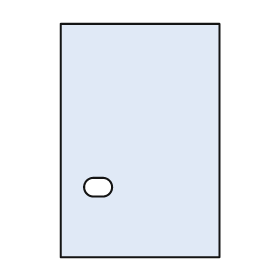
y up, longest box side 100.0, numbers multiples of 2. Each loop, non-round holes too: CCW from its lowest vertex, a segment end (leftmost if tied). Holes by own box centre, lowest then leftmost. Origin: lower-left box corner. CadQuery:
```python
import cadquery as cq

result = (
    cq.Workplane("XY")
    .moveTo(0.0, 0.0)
    .lineTo(68.0, 0.0)
    .lineTo(68.0, 100.0)
    .lineTo(0.0, 100.0)
    .close()
    .moveTo(14.0, 26.0)
    .lineTo(18.0, 26.0)
    .threePointArc((22.0, 30.0), (18.0, 34.0))
    .lineTo(14.0, 34.0)
    .threePointArc((10.0, 30.0), (14.0, 26.0))
    .close()
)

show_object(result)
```